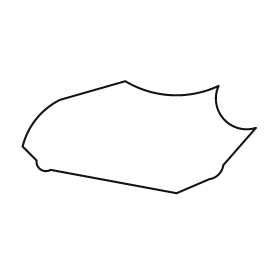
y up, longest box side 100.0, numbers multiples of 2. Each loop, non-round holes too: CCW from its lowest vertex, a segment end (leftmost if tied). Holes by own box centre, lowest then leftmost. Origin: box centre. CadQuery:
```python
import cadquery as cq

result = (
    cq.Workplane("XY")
    .moveTo(16.0, -24.0)
    .lineTo(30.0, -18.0)
    .threePointArc((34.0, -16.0), (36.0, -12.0))
    .lineTo(50.0, 4.0)
    .threePointArc((36.0, 8.0), (34.0, 22.0))
    .threePointArc((14.0, 18.0), (-6.0, 24.0))
    .lineTo(-34.0, 16.0)
    .threePointArc((-44.0, 8.0), (-50.0, -4.0))
    .lineTo(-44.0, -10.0)
    .threePointArc((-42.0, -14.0), (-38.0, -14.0))
    .close()
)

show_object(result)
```